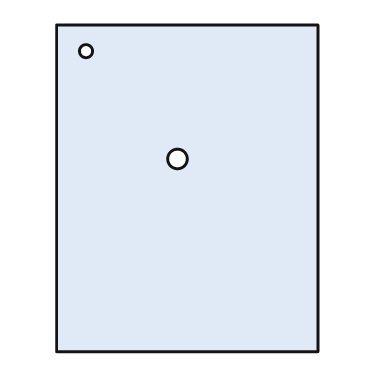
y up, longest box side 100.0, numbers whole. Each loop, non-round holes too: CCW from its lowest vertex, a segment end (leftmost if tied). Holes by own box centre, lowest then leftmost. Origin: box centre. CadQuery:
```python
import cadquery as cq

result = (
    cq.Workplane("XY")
    .moveTo(-40.0, -50.0)
    .lineTo(40.0, -50.0)
    .lineTo(40.0, 50.0)
    .lineTo(-40.0, 50.0)
    .close()
    .moveTo(-3.0, 9.0)
    .circle(3.0)
    .moveTo(-31.0, 42.0)
    .circle(2.0)
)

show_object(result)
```